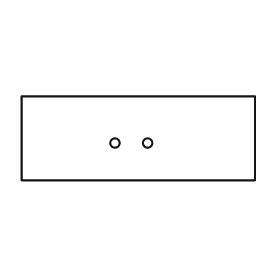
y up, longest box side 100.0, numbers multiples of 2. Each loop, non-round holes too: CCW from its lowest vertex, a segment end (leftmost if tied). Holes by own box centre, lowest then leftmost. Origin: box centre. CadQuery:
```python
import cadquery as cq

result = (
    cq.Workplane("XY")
    .moveTo(-50.0, -18.0)
    .lineTo(50.0, -18.0)
    .lineTo(50.0, 18.0)
    .lineTo(-50.0, 18.0)
    .close()
    .moveTo(-10.0, -2.0)
    .circle(2.0)
    .moveTo(4.0, -2.0)
    .circle(2.0)
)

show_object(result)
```